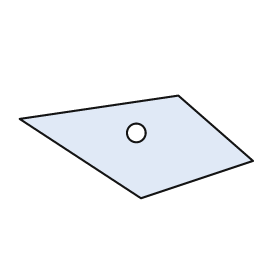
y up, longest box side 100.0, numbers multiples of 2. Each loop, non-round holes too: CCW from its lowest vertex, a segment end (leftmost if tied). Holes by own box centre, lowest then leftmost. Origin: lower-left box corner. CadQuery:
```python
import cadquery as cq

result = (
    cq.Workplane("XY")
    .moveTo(52.0, 0.0)
    .lineTo(100.0, 16.0)
    .lineTo(68.0, 44.0)
    .lineTo(0.0, 34.0)
    .close()
    .moveTo(50.0, 28.0)
    .circle(4.0)
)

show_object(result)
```